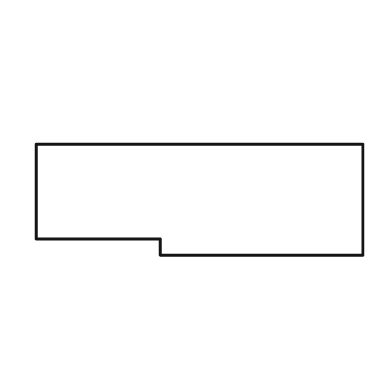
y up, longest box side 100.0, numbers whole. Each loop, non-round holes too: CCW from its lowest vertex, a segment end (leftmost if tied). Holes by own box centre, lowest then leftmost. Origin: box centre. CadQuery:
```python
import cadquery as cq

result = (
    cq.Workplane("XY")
    .moveTo(-12.0, -17.0)
    .lineTo(50.0, -17.0)
    .lineTo(50.0, 17.0)
    .lineTo(-50.0, 17.0)
    .lineTo(-50.0, -12.0)
    .lineTo(-12.0, -12.0)
    .close()
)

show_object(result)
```